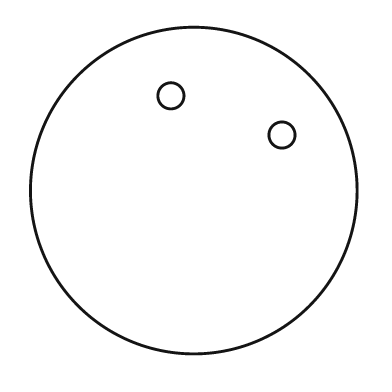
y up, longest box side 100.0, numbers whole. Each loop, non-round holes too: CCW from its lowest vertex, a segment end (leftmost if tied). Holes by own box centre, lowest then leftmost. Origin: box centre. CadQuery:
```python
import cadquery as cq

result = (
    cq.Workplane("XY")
    .moveTo(0.0, 0.0)
    .circle(50.0)
    .moveTo(27.0, 17.0)
    .circle(4.0)
    .moveTo(-7.0, 29.0)
    .circle(4.0)
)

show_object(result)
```